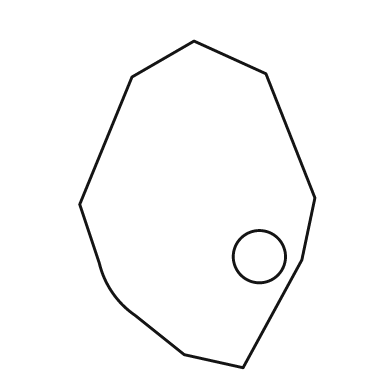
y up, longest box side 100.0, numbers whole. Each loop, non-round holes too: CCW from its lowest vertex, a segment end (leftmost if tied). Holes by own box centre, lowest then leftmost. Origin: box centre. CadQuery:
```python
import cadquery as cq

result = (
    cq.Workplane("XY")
    .moveTo(14.0, -50.0)
    .lineTo(32.0, -17.0)
    .lineTo(36.0, 2.0)
    .lineTo(21.0, 40.0)
    .lineTo(-1.0, 50.0)
    .lineTo(-20.0, 39.0)
    .lineTo(-36.0, 0.0)
    .lineTo(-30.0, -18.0)
    .threePointArc((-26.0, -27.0), (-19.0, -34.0))
    .lineTo(-4.0, -46.0)
    .close()
    .moveTo(19.0, -16.0)
    .circle(8.0)
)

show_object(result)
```